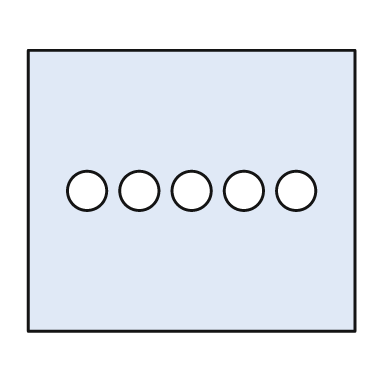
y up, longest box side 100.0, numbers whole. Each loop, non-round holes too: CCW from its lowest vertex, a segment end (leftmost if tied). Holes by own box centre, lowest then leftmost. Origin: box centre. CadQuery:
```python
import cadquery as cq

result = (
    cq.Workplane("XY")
    .moveTo(-50.0, -43.0)
    .lineTo(50.0, -43.0)
    .lineTo(50.0, 43.0)
    .lineTo(-50.0, 43.0)
    .close()
    .moveTo(-32.0, 0.0)
    .circle(6.0)
    .moveTo(-16.0, 0.0)
    .circle(6.0)
    .moveTo(0.0, 0.0)
    .circle(6.0)
    .moveTo(16.0, 0.0)
    .circle(6.0)
    .moveTo(32.0, 0.0)
    .circle(6.0)
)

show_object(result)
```